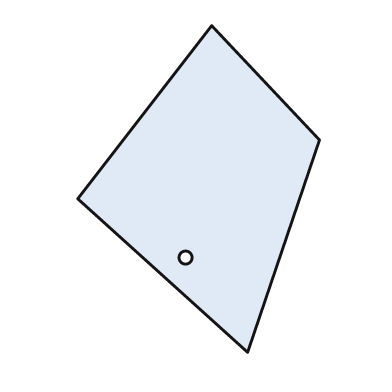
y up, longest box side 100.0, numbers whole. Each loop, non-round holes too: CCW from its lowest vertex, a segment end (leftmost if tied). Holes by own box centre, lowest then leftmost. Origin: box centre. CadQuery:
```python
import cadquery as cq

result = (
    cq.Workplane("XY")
    .moveTo(15.0, -50.0)
    .lineTo(37.0, 15.0)
    .lineTo(4.0, 50.0)
    .lineTo(-37.0, -3.0)
    .close()
    .moveTo(-4.0, -21.0)
    .circle(2.0)
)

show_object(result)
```